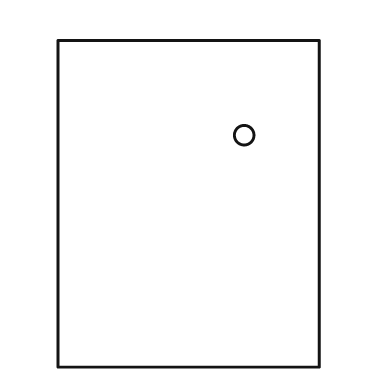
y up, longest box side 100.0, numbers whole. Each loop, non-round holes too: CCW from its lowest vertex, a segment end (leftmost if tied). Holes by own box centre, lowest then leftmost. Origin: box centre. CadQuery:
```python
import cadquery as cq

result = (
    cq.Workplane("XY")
    .moveTo(-40.0, -50.0)
    .lineTo(40.0, -50.0)
    .lineTo(40.0, 50.0)
    .lineTo(-40.0, 50.0)
    .close()
    .moveTo(17.0, 21.0)
    .circle(3.0)
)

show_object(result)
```